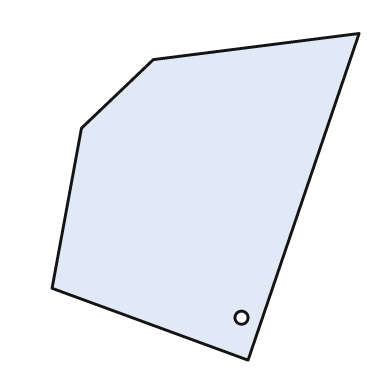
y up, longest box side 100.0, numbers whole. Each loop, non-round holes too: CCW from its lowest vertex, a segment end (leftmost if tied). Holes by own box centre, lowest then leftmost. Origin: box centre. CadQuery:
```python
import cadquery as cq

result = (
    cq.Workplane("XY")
    .moveTo(13.0, -50.0)
    .lineTo(47.0, 50.0)
    .lineTo(-16.0, 42.0)
    .lineTo(-38.0, 21.0)
    .lineTo(-47.0, -28.0)
    .close()
    .moveTo(11.0, -37.0)
    .circle(2.0)
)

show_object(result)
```